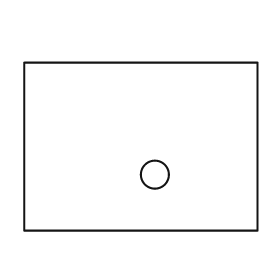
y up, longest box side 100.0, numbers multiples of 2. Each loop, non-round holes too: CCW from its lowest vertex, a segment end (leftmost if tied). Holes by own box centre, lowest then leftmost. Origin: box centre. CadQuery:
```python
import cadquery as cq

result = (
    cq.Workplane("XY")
    .moveTo(-50.0, -36.0)
    .lineTo(50.0, -36.0)
    .lineTo(50.0, 36.0)
    .lineTo(-50.0, 36.0)
    .close()
    .moveTo(6.0, -12.0)
    .circle(6.0)
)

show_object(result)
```